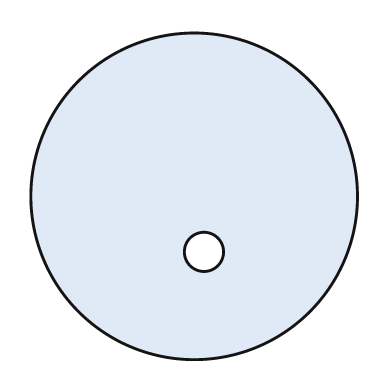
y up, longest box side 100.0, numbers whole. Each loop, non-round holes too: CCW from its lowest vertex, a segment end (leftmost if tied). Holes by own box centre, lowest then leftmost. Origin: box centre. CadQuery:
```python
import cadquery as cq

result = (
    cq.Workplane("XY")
    .moveTo(0.0, 0.0)
    .circle(50.0)
    .moveTo(3.0, -17.0)
    .circle(6.0)
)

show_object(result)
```